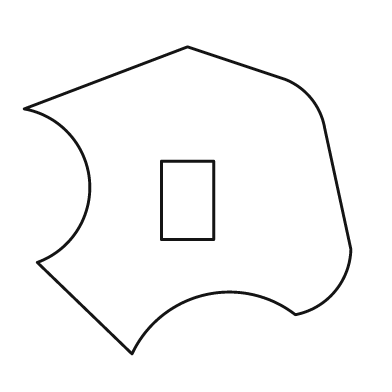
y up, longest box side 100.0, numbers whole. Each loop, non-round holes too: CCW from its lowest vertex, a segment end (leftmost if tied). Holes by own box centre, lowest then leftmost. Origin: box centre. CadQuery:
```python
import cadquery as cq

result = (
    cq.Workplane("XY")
    .moveTo(-17.0, -47.0)
    .threePointArc((5.0, -29.0), (33.0, -35.0))
    .threePointArc((45.0, -28.0), (50.0, -15.0))
    .lineTo(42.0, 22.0)
    .threePointArc((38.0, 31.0), (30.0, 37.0))
    .lineTo(0.0, 47.0)
    .lineTo(-50.0, 28.0)
    .threePointArc((-30.0, 6.0), (-46.0, -19.0))
    .close()
    .moveTo(-8.0, -12.0)
    .lineTo(8.0, -12.0)
    .lineTo(8.0, 12.0)
    .lineTo(-8.0, 12.0)
    .close()
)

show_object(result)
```